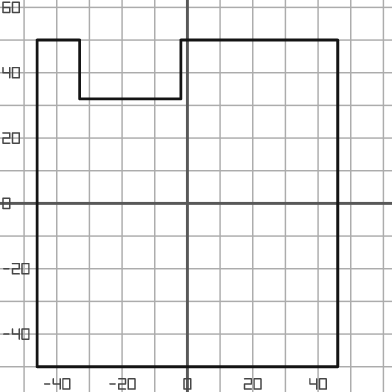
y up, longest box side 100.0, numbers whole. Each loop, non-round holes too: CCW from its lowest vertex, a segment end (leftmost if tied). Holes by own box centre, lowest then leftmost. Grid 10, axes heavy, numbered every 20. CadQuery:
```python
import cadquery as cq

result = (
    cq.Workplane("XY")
    .moveTo(-46.0, -50.0)
    .lineTo(46.0, -50.0)
    .lineTo(46.0, 50.0)
    .lineTo(-2.0, 50.0)
    .lineTo(-2.0, 32.0)
    .lineTo(-33.0, 32.0)
    .lineTo(-33.0, 50.0)
    .lineTo(-46.0, 50.0)
    .close()
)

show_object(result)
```